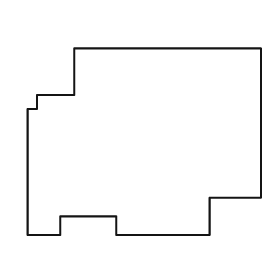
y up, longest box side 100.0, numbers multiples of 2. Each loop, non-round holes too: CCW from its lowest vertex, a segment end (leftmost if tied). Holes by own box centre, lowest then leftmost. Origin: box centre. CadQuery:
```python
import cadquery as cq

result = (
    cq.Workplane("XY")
    .moveTo(-50.0, -40.0)
    .lineTo(-36.0, -40.0)
    .lineTo(-36.0, -32.0)
    .lineTo(-12.0, -32.0)
    .lineTo(-12.0, -40.0)
    .lineTo(28.0, -40.0)
    .lineTo(28.0, -24.0)
    .lineTo(50.0, -24.0)
    .lineTo(50.0, 40.0)
    .lineTo(-30.0, 40.0)
    .lineTo(-30.0, 20.0)
    .lineTo(-46.0, 20.0)
    .lineTo(-46.0, 14.0)
    .lineTo(-50.0, 14.0)
    .close()
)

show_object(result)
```